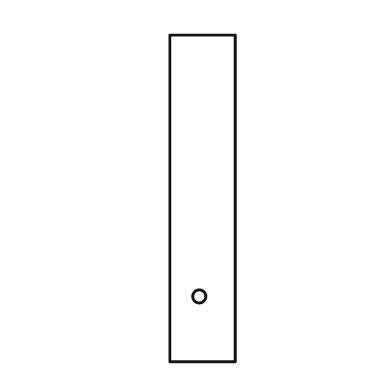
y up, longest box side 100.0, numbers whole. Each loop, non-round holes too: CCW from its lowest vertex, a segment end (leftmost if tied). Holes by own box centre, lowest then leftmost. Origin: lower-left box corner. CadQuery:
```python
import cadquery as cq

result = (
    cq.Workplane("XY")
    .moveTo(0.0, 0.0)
    .lineTo(20.0, 0.0)
    .lineTo(20.0, 100.0)
    .lineTo(0.0, 100.0)
    .close()
    .moveTo(9.0, 20.0)
    .circle(2.0)
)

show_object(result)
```